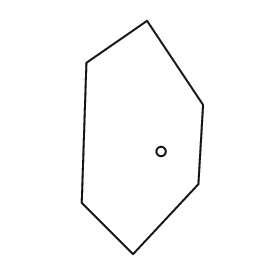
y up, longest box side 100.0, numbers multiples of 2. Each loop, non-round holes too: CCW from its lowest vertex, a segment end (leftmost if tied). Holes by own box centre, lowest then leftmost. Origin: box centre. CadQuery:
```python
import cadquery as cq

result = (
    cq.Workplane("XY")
    .moveTo(-4.0, -50.0)
    .lineTo(24.0, -20.0)
    .lineTo(26.0, 14.0)
    .lineTo(2.0, 50.0)
    .lineTo(-24.0, 32.0)
    .lineTo(-26.0, -28.0)
    .close()
    .moveTo(8.0, -6.0)
    .circle(2.0)
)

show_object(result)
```